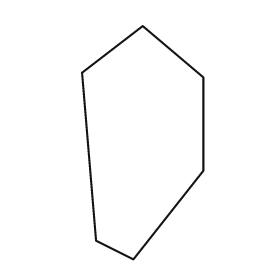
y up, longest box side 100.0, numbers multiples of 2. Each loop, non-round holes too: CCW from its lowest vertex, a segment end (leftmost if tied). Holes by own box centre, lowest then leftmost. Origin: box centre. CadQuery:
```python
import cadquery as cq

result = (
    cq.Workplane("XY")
    .moveTo(-4.0, -50.0)
    .lineTo(26.0, -12.0)
    .lineTo(26.0, 28.0)
    .lineTo(0.0, 50.0)
    .lineTo(-26.0, 30.0)
    .lineTo(-20.0, -42.0)
    .close()
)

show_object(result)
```